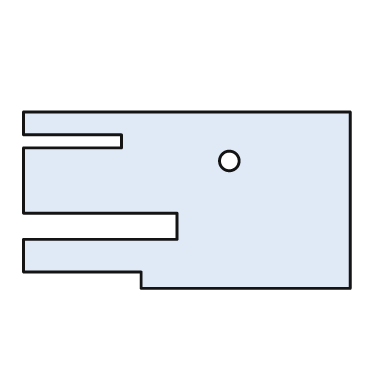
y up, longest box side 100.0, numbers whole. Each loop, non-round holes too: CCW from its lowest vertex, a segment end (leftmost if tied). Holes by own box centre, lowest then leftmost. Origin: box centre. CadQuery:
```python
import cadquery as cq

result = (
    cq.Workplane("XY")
    .moveTo(-14.0, -27.0)
    .lineTo(50.0, -27.0)
    .lineTo(50.0, 27.0)
    .lineTo(-50.0, 27.0)
    .lineTo(-50.0, 20.0)
    .lineTo(-20.0, 20.0)
    .lineTo(-20.0, 16.0)
    .lineTo(-50.0, 16.0)
    .lineTo(-50.0, -4.0)
    .lineTo(-3.0, -4.0)
    .lineTo(-3.0, -12.0)
    .lineTo(-50.0, -12.0)
    .lineTo(-50.0, -22.0)
    .lineTo(-14.0, -22.0)
    .close()
    .moveTo(13.0, 12.0)
    .circle(3.0)
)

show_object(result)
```